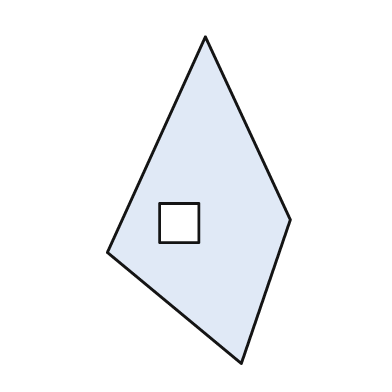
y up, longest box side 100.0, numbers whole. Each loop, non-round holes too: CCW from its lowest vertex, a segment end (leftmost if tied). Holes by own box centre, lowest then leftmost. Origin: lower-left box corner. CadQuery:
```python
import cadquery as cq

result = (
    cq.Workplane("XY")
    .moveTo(41.0, 0.0)
    .lineTo(56.0, 44.0)
    .lineTo(30.0, 100.0)
    .lineTo(0.0, 34.0)
    .close()
    .moveTo(16.0, 37.0)
    .lineTo(28.0, 37.0)
    .lineTo(28.0, 49.0)
    .lineTo(16.0, 49.0)
    .close()
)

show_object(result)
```